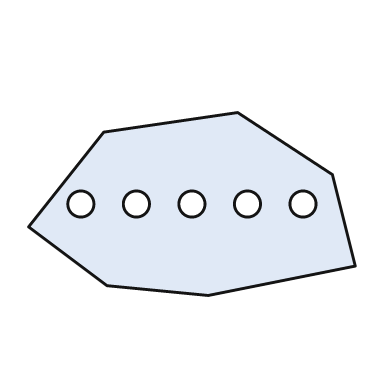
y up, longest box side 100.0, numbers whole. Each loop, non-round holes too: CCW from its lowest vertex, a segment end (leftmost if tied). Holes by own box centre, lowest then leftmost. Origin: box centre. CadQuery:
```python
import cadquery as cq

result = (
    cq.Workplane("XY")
    .moveTo(5.0, -28.0)
    .lineTo(50.0, -19.0)
    .lineTo(43.0, 9.0)
    .lineTo(14.0, 28.0)
    .lineTo(-27.0, 22.0)
    .lineTo(-50.0, -7.0)
    .lineTo(-26.0, -25.0)
    .close()
    .moveTo(-34.0, 0.0)
    .circle(4.0)
    .moveTo(-17.0, 0.0)
    .circle(4.0)
    .moveTo(0.0, 0.0)
    .circle(4.0)
    .moveTo(17.0, 0.0)
    .circle(4.0)
    .moveTo(34.0, 0.0)
    .circle(4.0)
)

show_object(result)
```